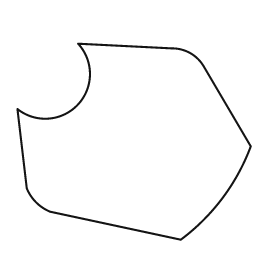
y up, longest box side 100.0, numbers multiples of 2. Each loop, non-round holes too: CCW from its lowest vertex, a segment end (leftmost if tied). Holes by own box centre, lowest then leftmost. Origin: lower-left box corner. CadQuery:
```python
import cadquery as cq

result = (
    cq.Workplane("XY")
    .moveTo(70.0, 0.0)
    .threePointArc((88.0, 18.0), (100.0, 40.0))
    .lineTo(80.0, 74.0)
    .threePointArc((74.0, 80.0), (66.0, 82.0))
    .lineTo(26.0, 84.0)
    .threePointArc((26.0, 58.0), (0.0, 56.0))
    .lineTo(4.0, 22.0)
    .threePointArc((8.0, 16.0), (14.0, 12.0))
    .close()
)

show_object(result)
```